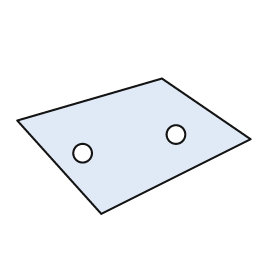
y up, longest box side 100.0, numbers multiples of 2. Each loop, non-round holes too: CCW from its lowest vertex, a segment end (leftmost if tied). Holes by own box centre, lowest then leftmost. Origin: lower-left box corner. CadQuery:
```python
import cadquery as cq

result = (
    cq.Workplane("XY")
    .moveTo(36.0, 0.0)
    .lineTo(100.0, 32.0)
    .lineTo(62.0, 58.0)
    .lineTo(0.0, 40.0)
    .close()
    .moveTo(28.0, 26.0)
    .circle(4.0)
    .moveTo(68.0, 34.0)
    .circle(4.0)
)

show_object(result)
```